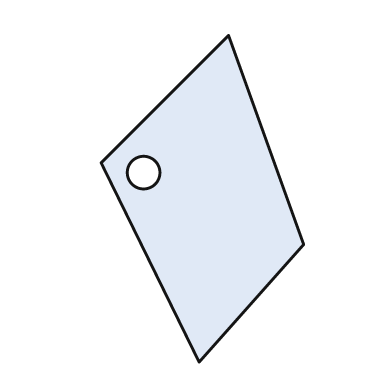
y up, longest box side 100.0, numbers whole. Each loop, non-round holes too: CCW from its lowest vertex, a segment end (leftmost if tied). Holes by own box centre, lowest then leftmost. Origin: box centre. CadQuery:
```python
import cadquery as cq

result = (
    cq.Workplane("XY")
    .moveTo(-1.0, -50.0)
    .lineTo(31.0, -14.0)
    .lineTo(8.0, 50.0)
    .lineTo(-31.0, 11.0)
    .close()
    .moveTo(-18.0, 8.0)
    .circle(5.0)
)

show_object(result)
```